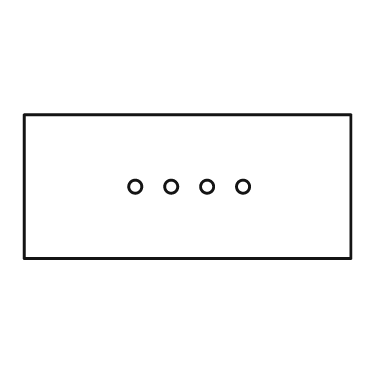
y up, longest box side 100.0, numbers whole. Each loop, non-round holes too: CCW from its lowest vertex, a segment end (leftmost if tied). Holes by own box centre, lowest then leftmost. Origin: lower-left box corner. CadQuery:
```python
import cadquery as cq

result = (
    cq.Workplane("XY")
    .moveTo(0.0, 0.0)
    .lineTo(100.0, 0.0)
    .lineTo(100.0, 44.0)
    .lineTo(0.0, 44.0)
    .close()
    .moveTo(34.0, 22.0)
    .circle(2.0)
    .moveTo(45.0, 22.0)
    .circle(2.0)
    .moveTo(56.0, 22.0)
    .circle(2.0)
    .moveTo(67.0, 22.0)
    .circle(2.0)
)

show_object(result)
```